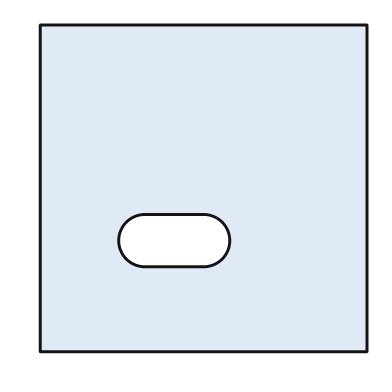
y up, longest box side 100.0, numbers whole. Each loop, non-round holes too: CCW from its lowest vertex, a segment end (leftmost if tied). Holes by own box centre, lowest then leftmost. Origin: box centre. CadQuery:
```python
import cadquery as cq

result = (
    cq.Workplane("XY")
    .moveTo(-50.0, -50.0)
    .lineTo(50.0, -50.0)
    .lineTo(50.0, 50.0)
    .lineTo(-50.0, 50.0)
    .close()
    .moveTo(-18.0, -24.0)
    .lineTo(0.0, -24.0)
    .threePointArc((8.0, -16.0), (0.0, -8.0))
    .lineTo(-18.0, -8.0)
    .threePointArc((-26.0, -16.0), (-18.0, -24.0))
    .close()
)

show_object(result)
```